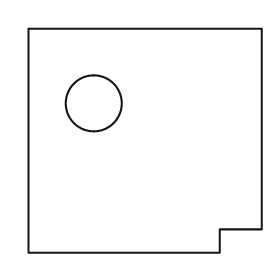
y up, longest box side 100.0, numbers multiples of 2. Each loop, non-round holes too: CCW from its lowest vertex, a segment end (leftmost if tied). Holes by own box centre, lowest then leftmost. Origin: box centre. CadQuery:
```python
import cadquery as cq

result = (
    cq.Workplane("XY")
    .moveTo(-50.0, -48.0)
    .lineTo(32.0, -48.0)
    .lineTo(32.0, -38.0)
    .lineTo(50.0, -38.0)
    .lineTo(50.0, 48.0)
    .lineTo(-50.0, 48.0)
    .close()
    .moveTo(-22.0, 16.0)
    .circle(12.0)
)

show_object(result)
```